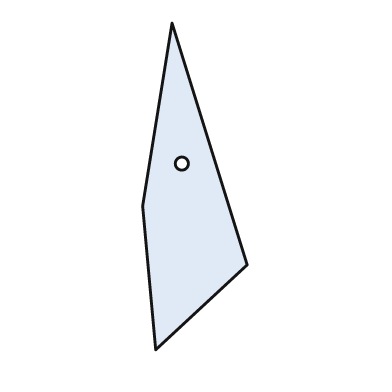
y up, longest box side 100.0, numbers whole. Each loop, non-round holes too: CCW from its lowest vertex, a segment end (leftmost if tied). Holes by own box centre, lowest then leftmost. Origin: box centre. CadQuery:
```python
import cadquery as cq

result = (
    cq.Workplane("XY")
    .moveTo(-12.0, -50.0)
    .lineTo(16.0, -24.0)
    .lineTo(-7.0, 50.0)
    .lineTo(-16.0, -6.0)
    .close()
    .moveTo(-4.0, 7.0)
    .circle(2.0)
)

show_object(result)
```